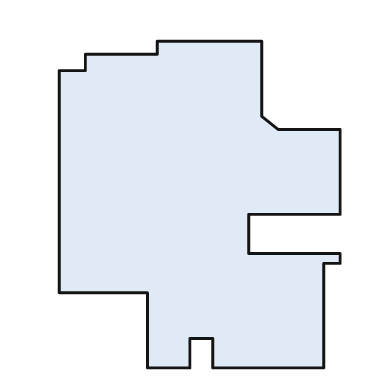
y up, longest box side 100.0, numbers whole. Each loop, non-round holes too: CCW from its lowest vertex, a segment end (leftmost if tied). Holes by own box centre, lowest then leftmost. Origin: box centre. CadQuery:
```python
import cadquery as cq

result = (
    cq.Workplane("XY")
    .moveTo(-16.0, -50.0)
    .lineTo(-3.0, -50.0)
    .lineTo(-3.0, -41.0)
    .lineTo(4.0, -41.0)
    .lineTo(4.0, -50.0)
    .lineTo(38.0, -50.0)
    .lineTo(38.0, -18.0)
    .lineTo(43.0, -18.0)
    .lineTo(43.0, -15.0)
    .lineTo(15.0, -15.0)
    .lineTo(15.0, -3.0)
    .lineTo(43.0, -3.0)
    .lineTo(43.0, 23.0)
    .lineTo(24.0, 23.0)
    .lineTo(19.0, 27.0)
    .lineTo(19.0, 50.0)
    .lineTo(-13.0, 50.0)
    .lineTo(-13.0, 46.0)
    .lineTo(-35.0, 46.0)
    .lineTo(-35.0, 41.0)
    .lineTo(-43.0, 41.0)
    .lineTo(-43.0, -27.0)
    .lineTo(-16.0, -27.0)
    .close()
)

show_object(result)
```